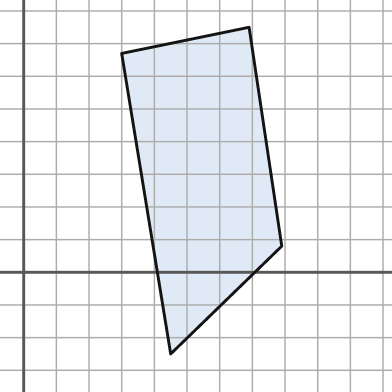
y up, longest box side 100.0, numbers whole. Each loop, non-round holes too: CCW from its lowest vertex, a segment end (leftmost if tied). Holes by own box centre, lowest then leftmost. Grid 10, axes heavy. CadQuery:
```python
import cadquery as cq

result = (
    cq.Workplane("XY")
    .moveTo(45.0, -25.0)
    .lineTo(79.0, 8.0)
    .lineTo(69.0, 75.0)
    .lineTo(30.0, 67.0)
    .close()
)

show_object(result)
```